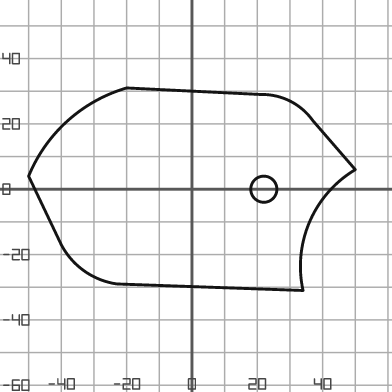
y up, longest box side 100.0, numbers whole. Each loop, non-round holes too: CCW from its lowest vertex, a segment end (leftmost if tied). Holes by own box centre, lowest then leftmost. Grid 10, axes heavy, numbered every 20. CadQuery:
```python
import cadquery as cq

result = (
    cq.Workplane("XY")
    .moveTo(34.0, -31.0)
    .threePointArc((36.0, -10.0), (50.0, 6.0))
    .lineTo(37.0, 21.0)
    .threePointArc((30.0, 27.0), (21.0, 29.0))
    .lineTo(-20.0, 31.0)
    .threePointArc((-38.0, 21.0), (-50.0, 4.0))
    .lineTo(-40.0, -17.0)
    .threePointArc((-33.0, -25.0), (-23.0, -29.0))
    .close()
    .moveTo(22.0, 0.0)
    .circle(4.0)
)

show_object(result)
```